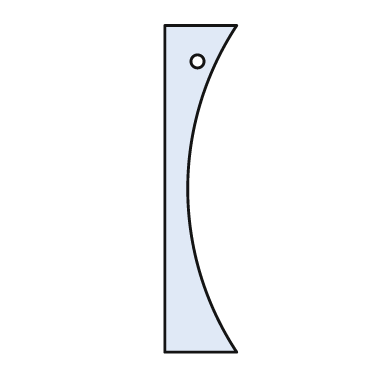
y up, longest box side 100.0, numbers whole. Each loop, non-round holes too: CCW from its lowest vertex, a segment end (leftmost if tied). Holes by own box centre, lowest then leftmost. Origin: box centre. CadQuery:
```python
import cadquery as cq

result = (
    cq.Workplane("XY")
    .moveTo(-11.0, -50.0)
    .lineTo(11.0, -50.0)
    .threePointArc((-4.0, 0.0), (11.0, 50.0))
    .lineTo(-11.0, 50.0)
    .close()
    .moveTo(-1.0, 39.0)
    .circle(2.0)
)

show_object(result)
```